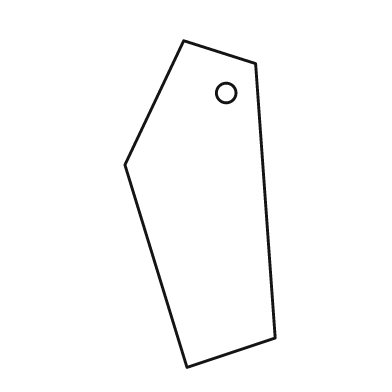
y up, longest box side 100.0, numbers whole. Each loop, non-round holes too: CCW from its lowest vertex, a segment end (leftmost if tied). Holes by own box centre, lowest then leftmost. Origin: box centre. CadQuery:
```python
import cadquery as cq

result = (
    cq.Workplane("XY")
    .moveTo(-4.0, -50.0)
    .lineTo(23.0, -41.0)
    .lineTo(17.0, 43.0)
    .lineTo(-5.0, 50.0)
    .lineTo(-23.0, 12.0)
    .close()
    .moveTo(8.0, 34.0)
    .circle(3.0)
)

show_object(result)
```